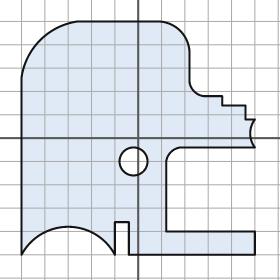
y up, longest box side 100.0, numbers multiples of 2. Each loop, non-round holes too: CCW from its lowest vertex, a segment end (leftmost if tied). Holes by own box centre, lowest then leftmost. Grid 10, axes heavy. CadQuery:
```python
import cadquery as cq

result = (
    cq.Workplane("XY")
    .moveTo(-50.0, -50.0)
    .threePointArc((-30.0, -38.0), (-10.0, -50.0))
    .lineTo(-10.0, -36.0)
    .lineTo(-4.0, -36.0)
    .lineTo(-4.0, -50.0)
    .lineTo(50.0, -50.0)
    .lineTo(50.0, -40.0)
    .lineTo(12.0, -40.0)
    .lineTo(12.0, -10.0)
    .threePointArc((14.0, -6.0), (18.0, -4.0))
    .lineTo(50.0, -4.0)
    .threePointArc((48.0, 2.0), (50.0, 8.0))
    .lineTo(46.0, 8.0)
    .lineTo(46.0, 14.0)
    .lineTo(36.0, 14.0)
    .lineTo(36.0, 18.0)
    .lineTo(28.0, 18.0)
    .threePointArc((24.0, 20.0), (22.0, 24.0))
    .lineTo(22.0, 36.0)
    .threePointArc((18.0, 46.0), (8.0, 50.0))
    .lineTo(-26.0, 50.0)
    .threePointArc((-42.0, 42.0), (-50.0, 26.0))
    .close()
    .moveTo(-2.0, -10.0)
    .circle(6.0)
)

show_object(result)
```